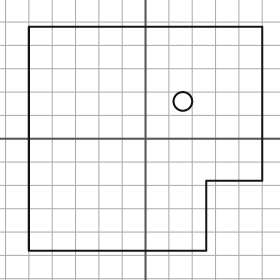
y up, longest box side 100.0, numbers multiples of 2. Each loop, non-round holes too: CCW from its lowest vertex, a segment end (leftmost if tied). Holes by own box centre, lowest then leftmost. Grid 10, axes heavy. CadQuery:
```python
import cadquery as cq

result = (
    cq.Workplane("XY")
    .moveTo(-50.0, -48.0)
    .lineTo(26.0, -48.0)
    .lineTo(26.0, -18.0)
    .lineTo(50.0, -18.0)
    .lineTo(50.0, 48.0)
    .lineTo(-50.0, 48.0)
    .close()
    .moveTo(16.0, 16.0)
    .circle(4.0)
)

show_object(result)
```